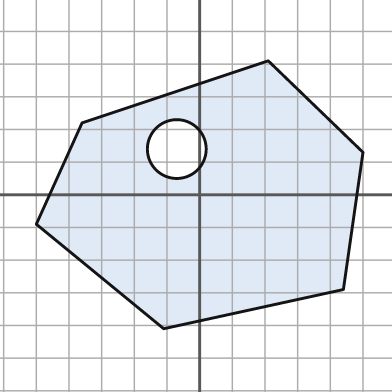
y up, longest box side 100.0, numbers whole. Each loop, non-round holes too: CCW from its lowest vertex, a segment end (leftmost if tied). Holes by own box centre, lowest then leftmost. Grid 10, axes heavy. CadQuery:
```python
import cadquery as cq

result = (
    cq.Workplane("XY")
    .moveTo(-11.0, -41.0)
    .lineTo(44.0, -29.0)
    .lineTo(50.0, 13.0)
    .lineTo(21.0, 41.0)
    .lineTo(-36.0, 22.0)
    .lineTo(-50.0, -9.0)
    .close()
    .moveTo(-7.0, 14.0)
    .circle(9.0)
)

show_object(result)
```